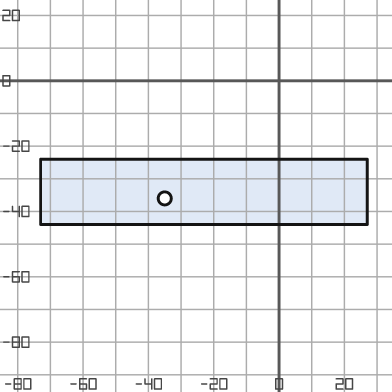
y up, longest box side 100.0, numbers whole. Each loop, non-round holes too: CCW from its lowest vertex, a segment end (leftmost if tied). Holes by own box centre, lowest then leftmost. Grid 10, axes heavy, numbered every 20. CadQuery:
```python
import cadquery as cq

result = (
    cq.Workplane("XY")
    .moveTo(-73.0, -44.0)
    .lineTo(27.0, -44.0)
    .lineTo(27.0, -24.0)
    .lineTo(-73.0, -24.0)
    .close()
    .moveTo(-35.0, -36.0)
    .circle(2.0)
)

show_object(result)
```